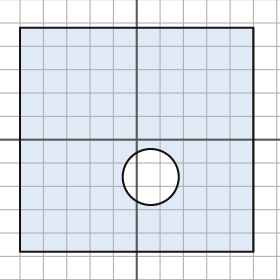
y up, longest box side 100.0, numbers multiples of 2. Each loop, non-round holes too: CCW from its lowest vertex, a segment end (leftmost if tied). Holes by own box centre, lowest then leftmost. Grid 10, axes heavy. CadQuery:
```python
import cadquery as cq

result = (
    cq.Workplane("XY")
    .moveTo(-50.0, -48.0)
    .lineTo(50.0, -48.0)
    .lineTo(50.0, 48.0)
    .lineTo(-50.0, 48.0)
    .close()
    .moveTo(6.0, -16.0)
    .circle(12.0)
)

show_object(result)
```